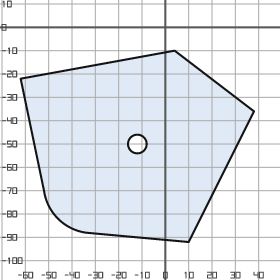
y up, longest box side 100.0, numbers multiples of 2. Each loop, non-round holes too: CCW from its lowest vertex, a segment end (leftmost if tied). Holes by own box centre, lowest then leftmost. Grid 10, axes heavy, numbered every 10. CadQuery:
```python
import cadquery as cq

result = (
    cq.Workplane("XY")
    .moveTo(10.0, -92.0)
    .lineTo(38.0, -36.0)
    .lineTo(4.0, -10.0)
    .lineTo(-62.0, -22.0)
    .lineTo(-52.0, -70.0)
    .threePointArc((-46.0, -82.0), (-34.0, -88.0))
    .close()
    .moveTo(-12.0, -50.0)
    .circle(4.0)
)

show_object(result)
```